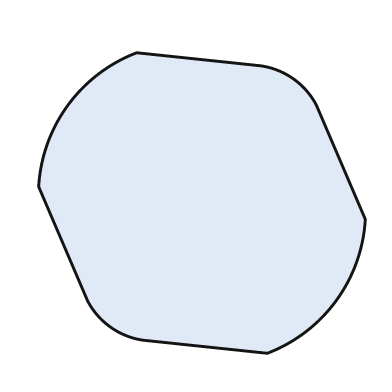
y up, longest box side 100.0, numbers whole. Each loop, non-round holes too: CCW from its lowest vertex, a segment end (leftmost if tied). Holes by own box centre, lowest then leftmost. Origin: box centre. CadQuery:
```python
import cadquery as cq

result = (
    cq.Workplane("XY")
    .moveTo(20.0, -46.0)
    .threePointArc((41.0, -30.0), (50.0, -5.0))
    .lineTo(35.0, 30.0)
    .threePointArc((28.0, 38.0), (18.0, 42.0))
    .lineTo(-20.0, 46.0)
    .threePointArc((-41.0, 30.0), (-50.0, 5.0))
    .lineTo(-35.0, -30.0)
    .threePointArc((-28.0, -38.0), (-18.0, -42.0))
    .close()
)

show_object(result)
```